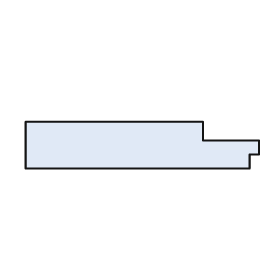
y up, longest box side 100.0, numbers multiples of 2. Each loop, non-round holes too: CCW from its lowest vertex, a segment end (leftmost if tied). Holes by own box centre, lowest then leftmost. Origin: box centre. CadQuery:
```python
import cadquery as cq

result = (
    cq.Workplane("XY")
    .moveTo(-50.0, -10.0)
    .lineTo(46.0, -10.0)
    .lineTo(46.0, -4.0)
    .lineTo(50.0, -4.0)
    .lineTo(50.0, 2.0)
    .lineTo(26.0, 2.0)
    .lineTo(26.0, 10.0)
    .lineTo(-50.0, 10.0)
    .close()
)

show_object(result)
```